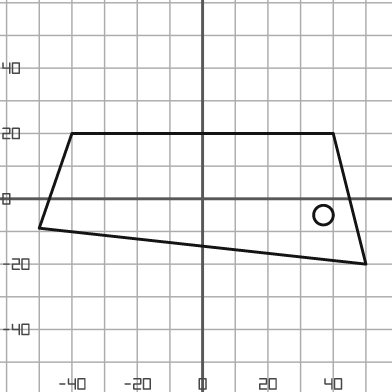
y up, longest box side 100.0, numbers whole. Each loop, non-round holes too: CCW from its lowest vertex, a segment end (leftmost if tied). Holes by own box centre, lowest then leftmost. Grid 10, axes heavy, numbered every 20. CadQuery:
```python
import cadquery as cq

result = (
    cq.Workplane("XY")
    .moveTo(50.0, -20.0)
    .lineTo(40.0, 20.0)
    .lineTo(-40.0, 20.0)
    .lineTo(-50.0, -9.0)
    .close()
    .moveTo(37.0, -5.0)
    .circle(3.0)
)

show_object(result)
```